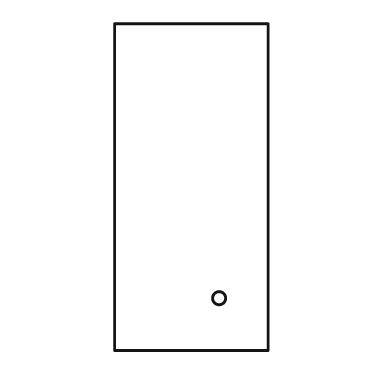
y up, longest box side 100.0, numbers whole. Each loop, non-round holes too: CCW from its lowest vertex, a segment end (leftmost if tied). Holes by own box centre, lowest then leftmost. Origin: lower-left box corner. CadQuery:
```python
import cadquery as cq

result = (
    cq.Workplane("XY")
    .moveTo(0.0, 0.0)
    .lineTo(47.0, 0.0)
    .lineTo(47.0, 100.0)
    .lineTo(0.0, 100.0)
    .close()
    .moveTo(32.0, 16.0)
    .circle(2.0)
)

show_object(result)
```